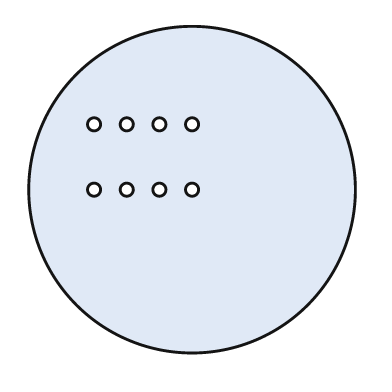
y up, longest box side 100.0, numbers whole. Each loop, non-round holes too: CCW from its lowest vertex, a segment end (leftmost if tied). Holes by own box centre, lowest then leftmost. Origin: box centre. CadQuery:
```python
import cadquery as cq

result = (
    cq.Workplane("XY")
    .moveTo(0.0, 0.0)
    .circle(50.0)
    .moveTo(-30.0, 0.0)
    .circle(2.0)
    .moveTo(-20.0, 0.0)
    .circle(2.0)
    .moveTo(-10.0, 0.0)
    .circle(2.0)
    .moveTo(0.0, 0.0)
    .circle(2.0)
    .moveTo(-30.0, 20.0)
    .circle(2.0)
    .moveTo(-20.0, 20.0)
    .circle(2.0)
    .moveTo(-10.0, 20.0)
    .circle(2.0)
    .moveTo(0.0, 20.0)
    .circle(2.0)
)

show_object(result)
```